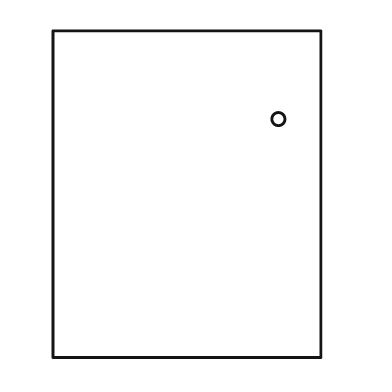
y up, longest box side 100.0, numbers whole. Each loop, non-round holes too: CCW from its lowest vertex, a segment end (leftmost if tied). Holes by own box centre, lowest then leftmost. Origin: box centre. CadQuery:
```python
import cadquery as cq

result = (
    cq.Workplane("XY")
    .moveTo(-41.0, -50.0)
    .lineTo(41.0, -50.0)
    .lineTo(41.0, 50.0)
    .lineTo(-41.0, 50.0)
    .close()
    .moveTo(28.0, 23.0)
    .circle(2.0)
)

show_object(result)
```